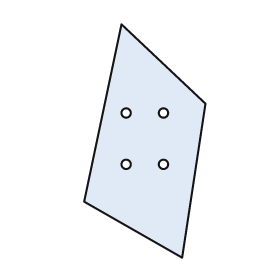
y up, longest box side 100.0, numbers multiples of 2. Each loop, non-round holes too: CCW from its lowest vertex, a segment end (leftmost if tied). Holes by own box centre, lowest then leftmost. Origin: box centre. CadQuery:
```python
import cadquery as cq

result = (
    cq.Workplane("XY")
    .moveTo(16.0, -50.0)
    .lineTo(26.0, 16.0)
    .lineTo(-10.0, 50.0)
    .lineTo(-26.0, -26.0)
    .close()
    .moveTo(-8.0, -10.0)
    .circle(2.0)
    .moveTo(8.0, -10.0)
    .circle(2.0)
    .moveTo(-8.0, 12.0)
    .circle(2.0)
    .moveTo(8.0, 12.0)
    .circle(2.0)
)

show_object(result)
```